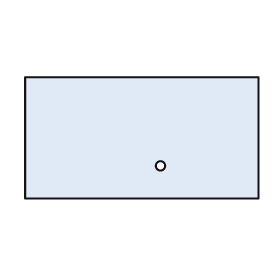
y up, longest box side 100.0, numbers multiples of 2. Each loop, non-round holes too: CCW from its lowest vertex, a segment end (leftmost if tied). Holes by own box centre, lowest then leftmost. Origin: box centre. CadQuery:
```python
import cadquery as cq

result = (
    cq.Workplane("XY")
    .moveTo(-50.0, -26.0)
    .lineTo(50.0, -26.0)
    .lineTo(50.0, 26.0)
    .lineTo(-50.0, 26.0)
    .close()
    .moveTo(8.0, -12.0)
    .circle(2.0)
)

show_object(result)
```